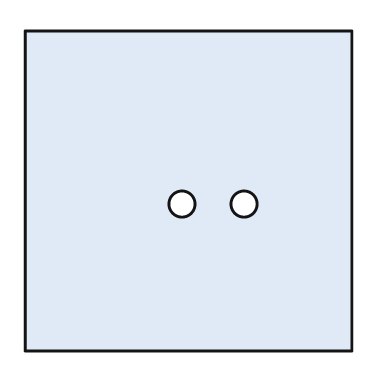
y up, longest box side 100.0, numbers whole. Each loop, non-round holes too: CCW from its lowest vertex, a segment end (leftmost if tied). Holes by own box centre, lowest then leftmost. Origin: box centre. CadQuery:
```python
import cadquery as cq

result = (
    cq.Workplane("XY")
    .moveTo(-50.0, -49.0)
    .lineTo(50.0, -49.0)
    .lineTo(50.0, 49.0)
    .lineTo(-50.0, 49.0)
    .close()
    .moveTo(-2.0, -4.0)
    .circle(4.0)
    .moveTo(17.0, -4.0)
    .circle(4.0)
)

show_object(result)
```